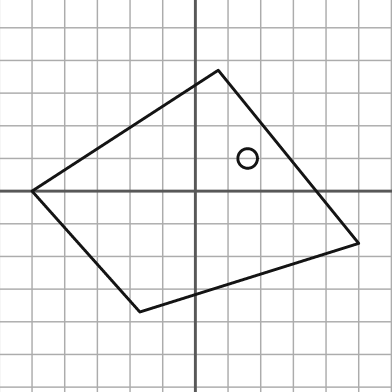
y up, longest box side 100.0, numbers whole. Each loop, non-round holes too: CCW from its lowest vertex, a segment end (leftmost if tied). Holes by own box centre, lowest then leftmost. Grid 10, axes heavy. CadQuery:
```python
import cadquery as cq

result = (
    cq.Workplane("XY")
    .moveTo(-17.0, -37.0)
    .lineTo(50.0, -16.0)
    .lineTo(7.0, 37.0)
    .lineTo(-50.0, 0.0)
    .close()
    .moveTo(16.0, 10.0)
    .circle(3.0)
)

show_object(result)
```